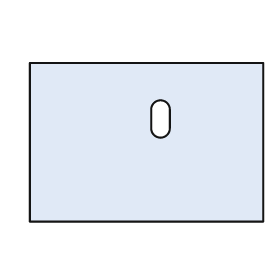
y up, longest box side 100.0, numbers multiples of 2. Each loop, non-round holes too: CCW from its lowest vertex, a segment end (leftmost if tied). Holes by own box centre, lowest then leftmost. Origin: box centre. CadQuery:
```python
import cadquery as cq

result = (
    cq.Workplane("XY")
    .moveTo(-50.0, -34.0)
    .lineTo(50.0, -34.0)
    .lineTo(50.0, 34.0)
    .lineTo(-50.0, 34.0)
    .close()
    .moveTo(2.0, 6.0)
    .threePointArc((6.0, 2.0), (10.0, 6.0))
    .lineTo(10.0, 14.0)
    .threePointArc((6.0, 18.0), (2.0, 14.0))
    .close()
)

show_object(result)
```